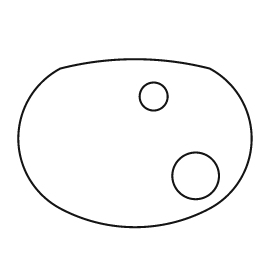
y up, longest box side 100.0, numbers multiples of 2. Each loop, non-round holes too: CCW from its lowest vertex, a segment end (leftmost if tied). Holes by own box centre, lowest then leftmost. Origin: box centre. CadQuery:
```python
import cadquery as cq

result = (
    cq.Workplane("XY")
    .moveTo(-32.0, -28.0)
    .threePointArc((0.0, -36.0), (32.0, -28.0))
    .threePointArc((50.0, 2.0), (32.0, 32.0))
    .threePointArc((0.0, 36.0), (-32.0, 32.0))
    .threePointArc((-50.0, 2.0), (-32.0, -28.0))
    .close()
    .moveTo(26.0, -14.0)
    .circle(10.0)
    .moveTo(8.0, 20.0)
    .circle(6.0)
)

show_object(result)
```